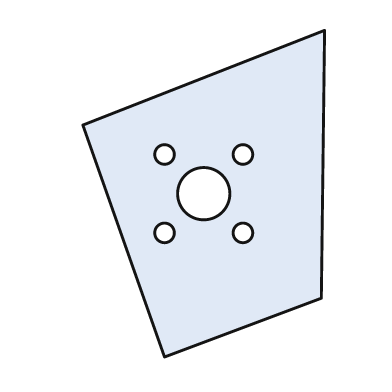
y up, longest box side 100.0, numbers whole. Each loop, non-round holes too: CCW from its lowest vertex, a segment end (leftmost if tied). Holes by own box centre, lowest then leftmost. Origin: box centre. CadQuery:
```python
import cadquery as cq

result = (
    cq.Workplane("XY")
    .moveTo(-12.0, -50.0)
    .lineTo(36.0, -32.0)
    .lineTo(37.0, 50.0)
    .lineTo(-37.0, 21.0)
    .close()
    .moveTo(-12.0, -12.0)
    .circle(3.0)
    .moveTo(12.0, -12.0)
    .circle(3.0)
    .moveTo(0.0, 0.0)
    .circle(8.0)
    .moveTo(-12.0, 12.0)
    .circle(3.0)
    .moveTo(12.0, 12.0)
    .circle(3.0)
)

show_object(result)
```